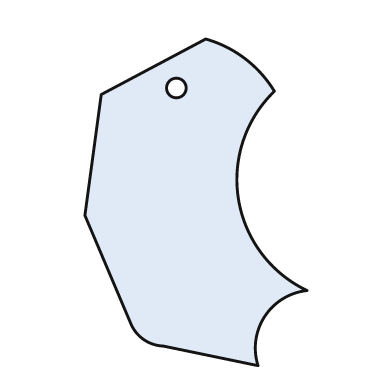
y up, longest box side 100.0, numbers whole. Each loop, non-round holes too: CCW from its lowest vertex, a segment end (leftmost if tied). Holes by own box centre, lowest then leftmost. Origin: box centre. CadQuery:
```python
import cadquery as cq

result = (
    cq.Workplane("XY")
    .moveTo(19.0, -50.0)
    .threePointArc((21.0, -35.0), (34.0, -27.0))
    .threePointArc((13.0, 1.0), (24.0, 34.0))
    .threePointArc((15.0, 44.0), (3.0, 50.0))
    .lineTo(-29.0, 33.0)
    .lineTo(-34.0, -4.0)
    .lineTo(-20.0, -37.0)
    .threePointArc((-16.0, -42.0), (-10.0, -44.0))
    .close()
    .moveTo(-6.0, 35.0)
    .circle(3.0)
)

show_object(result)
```